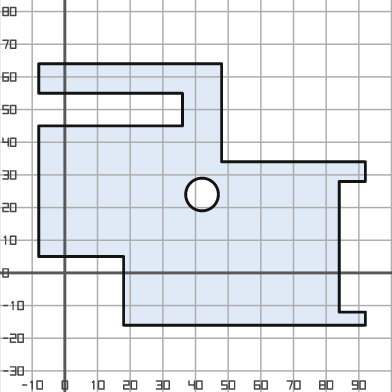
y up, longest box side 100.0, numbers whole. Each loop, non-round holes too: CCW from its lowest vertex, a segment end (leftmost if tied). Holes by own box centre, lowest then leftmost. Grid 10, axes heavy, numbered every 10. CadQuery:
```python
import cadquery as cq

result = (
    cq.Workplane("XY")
    .moveTo(18.0, -16.0)
    .lineTo(92.0, -16.0)
    .lineTo(92.0, -12.0)
    .lineTo(84.0, -12.0)
    .lineTo(84.0, 28.0)
    .lineTo(92.0, 28.0)
    .lineTo(92.0, 34.0)
    .lineTo(48.0, 34.0)
    .lineTo(48.0, 64.0)
    .lineTo(-8.0, 64.0)
    .lineTo(-8.0, 55.0)
    .lineTo(36.0, 55.0)
    .lineTo(36.0, 45.0)
    .lineTo(-8.0, 45.0)
    .lineTo(-8.0, 5.0)
    .lineTo(18.0, 5.0)
    .close()
    .moveTo(42.0, 24.0)
    .circle(5.0)
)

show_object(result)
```